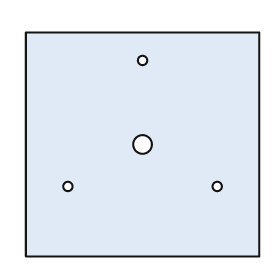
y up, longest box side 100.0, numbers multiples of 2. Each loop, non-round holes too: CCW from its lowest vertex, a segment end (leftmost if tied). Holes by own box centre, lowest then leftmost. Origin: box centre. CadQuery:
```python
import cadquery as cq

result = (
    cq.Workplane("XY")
    .moveTo(-50.0, -48.0)
    .lineTo(50.0, -48.0)
    .lineTo(50.0, 48.0)
    .lineTo(-50.0, 48.0)
    .close()
    .moveTo(-32.0, -18.0)
    .circle(2.0)
    .moveTo(32.0, -18.0)
    .circle(2.0)
    .moveTo(0.0, 0.0)
    .circle(4.0)
    .moveTo(0.0, 36.0)
    .circle(2.0)
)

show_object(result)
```